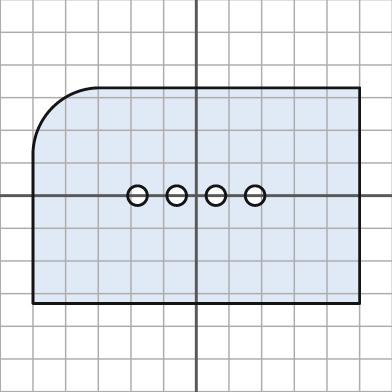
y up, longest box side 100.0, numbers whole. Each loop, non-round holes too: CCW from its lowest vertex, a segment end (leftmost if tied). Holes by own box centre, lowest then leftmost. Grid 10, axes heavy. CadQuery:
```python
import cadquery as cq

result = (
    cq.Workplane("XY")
    .moveTo(-50.0, -33.0)
    .lineTo(50.0, -33.0)
    .lineTo(50.0, 33.0)
    .lineTo(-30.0, 33.0)
    .threePointArc((-44.0, 27.0), (-50.0, 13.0))
    .close()
    .moveTo(-18.0, 0.0)
    .circle(3.0)
    .moveTo(-6.0, 0.0)
    .circle(3.0)
    .moveTo(6.0, 0.0)
    .circle(3.0)
    .moveTo(18.0, 0.0)
    .circle(3.0)
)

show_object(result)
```